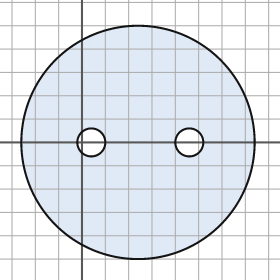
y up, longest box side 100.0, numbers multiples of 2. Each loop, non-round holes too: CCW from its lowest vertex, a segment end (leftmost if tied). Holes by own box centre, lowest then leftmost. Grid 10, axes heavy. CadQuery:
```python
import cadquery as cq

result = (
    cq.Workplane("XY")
    .moveTo(24.0, 0.0)
    .circle(50.0)
    .moveTo(4.0, 0.0)
    .circle(6.0)
    .moveTo(46.0, 0.0)
    .circle(6.0)
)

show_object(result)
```